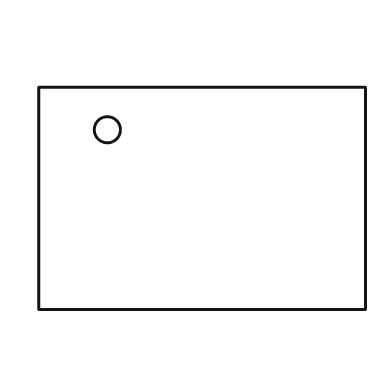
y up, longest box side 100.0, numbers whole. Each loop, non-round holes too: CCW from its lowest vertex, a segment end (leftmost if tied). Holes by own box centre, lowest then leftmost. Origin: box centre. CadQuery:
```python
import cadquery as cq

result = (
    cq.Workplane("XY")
    .moveTo(-50.0, -34.0)
    .lineTo(50.0, -34.0)
    .lineTo(50.0, 34.0)
    .lineTo(-50.0, 34.0)
    .close()
    .moveTo(-29.0, 21.0)
    .circle(4.0)
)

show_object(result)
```